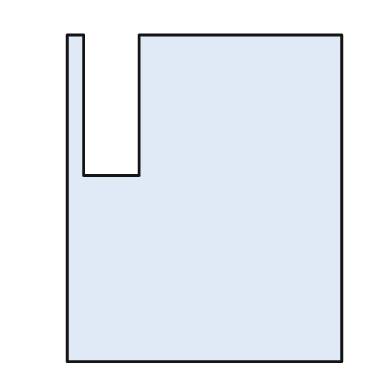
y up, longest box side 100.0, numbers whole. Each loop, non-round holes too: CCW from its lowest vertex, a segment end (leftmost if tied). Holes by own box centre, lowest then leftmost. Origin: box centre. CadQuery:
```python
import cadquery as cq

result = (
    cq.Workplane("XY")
    .moveTo(-42.0, -50.0)
    .lineTo(42.0, -50.0)
    .lineTo(42.0, 50.0)
    .lineTo(-20.0, 50.0)
    .lineTo(-20.0, 7.0)
    .lineTo(-37.0, 7.0)
    .lineTo(-37.0, 50.0)
    .lineTo(-42.0, 50.0)
    .close()
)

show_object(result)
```